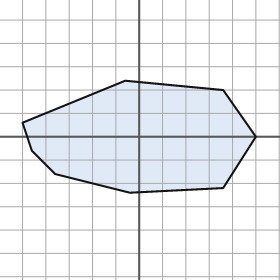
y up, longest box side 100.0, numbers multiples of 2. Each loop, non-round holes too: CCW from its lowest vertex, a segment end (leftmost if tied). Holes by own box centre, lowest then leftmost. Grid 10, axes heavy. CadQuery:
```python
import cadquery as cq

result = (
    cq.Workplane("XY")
    .moveTo(-4.0, -24.0)
    .lineTo(36.0, -22.0)
    .lineTo(50.0, 0.0)
    .lineTo(36.0, 20.0)
    .lineTo(-6.0, 24.0)
    .lineTo(-50.0, 6.0)
    .lineTo(-46.0, -6.0)
    .lineTo(-36.0, -16.0)
    .close()
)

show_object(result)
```